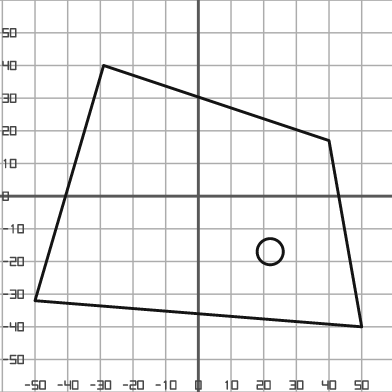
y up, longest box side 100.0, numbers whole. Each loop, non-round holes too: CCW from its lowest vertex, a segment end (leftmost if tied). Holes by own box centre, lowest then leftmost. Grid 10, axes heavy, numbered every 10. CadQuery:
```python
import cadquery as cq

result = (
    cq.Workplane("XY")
    .moveTo(50.0, -40.0)
    .lineTo(40.0, 17.0)
    .lineTo(-29.0, 40.0)
    .lineTo(-50.0, -32.0)
    .close()
    .moveTo(22.0, -17.0)
    .circle(4.0)
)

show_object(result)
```